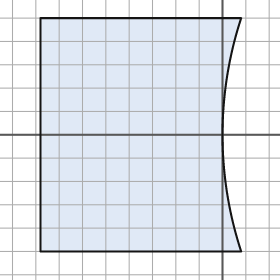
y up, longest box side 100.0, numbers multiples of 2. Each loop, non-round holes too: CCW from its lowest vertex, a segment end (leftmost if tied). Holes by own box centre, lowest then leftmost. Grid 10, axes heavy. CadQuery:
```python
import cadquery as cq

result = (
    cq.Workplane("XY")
    .moveTo(-78.0, -50.0)
    .lineTo(8.0, -50.0)
    .threePointArc((0.0, 0.0), (8.0, 50.0))
    .lineTo(-78.0, 50.0)
    .close()
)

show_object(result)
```